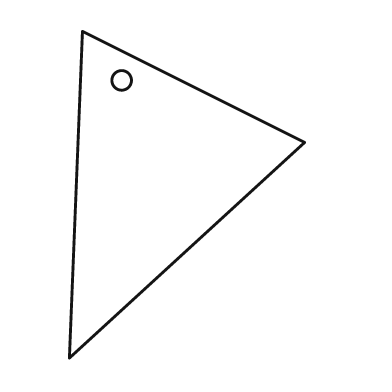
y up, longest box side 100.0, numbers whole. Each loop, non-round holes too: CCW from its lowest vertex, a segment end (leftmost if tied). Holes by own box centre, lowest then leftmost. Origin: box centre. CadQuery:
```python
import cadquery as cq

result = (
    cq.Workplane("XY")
    .moveTo(-36.0, -50.0)
    .lineTo(36.0, 16.0)
    .lineTo(-32.0, 50.0)
    .close()
    .moveTo(-20.0, 35.0)
    .circle(3.0)
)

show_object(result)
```